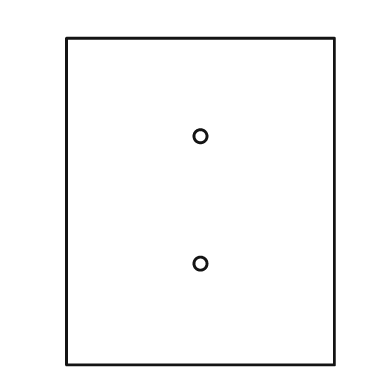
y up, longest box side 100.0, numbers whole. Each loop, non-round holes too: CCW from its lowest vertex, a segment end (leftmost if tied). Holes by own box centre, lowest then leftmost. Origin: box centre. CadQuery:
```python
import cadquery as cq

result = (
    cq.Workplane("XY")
    .moveTo(-41.0, -50.0)
    .lineTo(41.0, -50.0)
    .lineTo(41.0, 50.0)
    .lineTo(-41.0, 50.0)
    .close()
    .moveTo(0.0, -19.0)
    .circle(2.0)
    .moveTo(0.0, 20.0)
    .circle(2.0)
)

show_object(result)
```